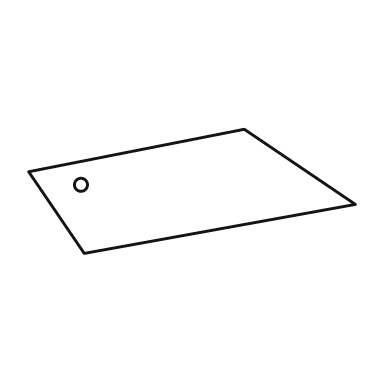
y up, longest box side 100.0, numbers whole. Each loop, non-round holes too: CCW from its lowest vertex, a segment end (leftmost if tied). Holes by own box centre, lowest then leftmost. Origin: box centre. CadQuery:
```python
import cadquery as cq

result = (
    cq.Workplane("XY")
    .moveTo(-33.0, -19.0)
    .lineTo(50.0, -4.0)
    .lineTo(16.0, 19.0)
    .lineTo(-50.0, 6.0)
    .close()
    .moveTo(-34.0, 2.0)
    .circle(2.0)
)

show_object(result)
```